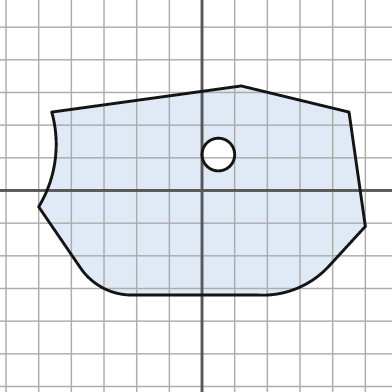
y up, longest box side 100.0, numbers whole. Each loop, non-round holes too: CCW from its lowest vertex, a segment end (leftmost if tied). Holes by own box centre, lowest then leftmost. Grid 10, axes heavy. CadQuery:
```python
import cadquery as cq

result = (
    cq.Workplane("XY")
    .moveTo(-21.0, -32.0)
    .lineTo(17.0, -32.0)
    .threePointArc((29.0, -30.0), (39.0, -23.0))
    .lineTo(50.0, -11.0)
    .lineTo(45.0, 24.0)
    .lineTo(12.0, 32.0)
    .lineTo(-46.0, 24.0)
    .threePointArc((-45.0, 9.0), (-50.0, -5.0))
    .lineTo(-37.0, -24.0)
    .threePointArc((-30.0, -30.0), (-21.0, -32.0))
    .close()
    .moveTo(5.0, 11.0)
    .circle(5.0)
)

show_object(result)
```